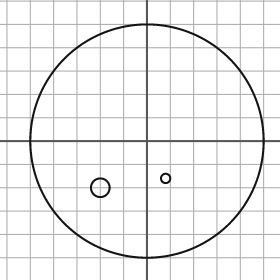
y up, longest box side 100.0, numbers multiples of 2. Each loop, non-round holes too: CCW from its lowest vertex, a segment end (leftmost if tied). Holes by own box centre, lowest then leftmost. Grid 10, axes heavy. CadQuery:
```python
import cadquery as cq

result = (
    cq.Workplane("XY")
    .moveTo(0.0, 0.0)
    .circle(50.0)
    .moveTo(-20.0, -20.0)
    .circle(4.0)
    .moveTo(8.0, -16.0)
    .circle(2.0)
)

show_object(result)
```